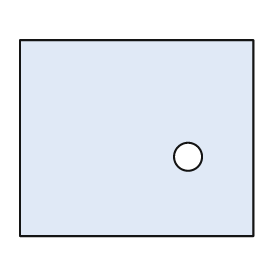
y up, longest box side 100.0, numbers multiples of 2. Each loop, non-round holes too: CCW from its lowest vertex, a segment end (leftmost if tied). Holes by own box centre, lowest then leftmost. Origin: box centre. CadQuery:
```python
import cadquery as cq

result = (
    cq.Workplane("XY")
    .moveTo(-50.0, -42.0)
    .lineTo(50.0, -42.0)
    .lineTo(50.0, 42.0)
    .lineTo(-50.0, 42.0)
    .close()
    .moveTo(22.0, -8.0)
    .circle(6.0)
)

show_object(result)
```